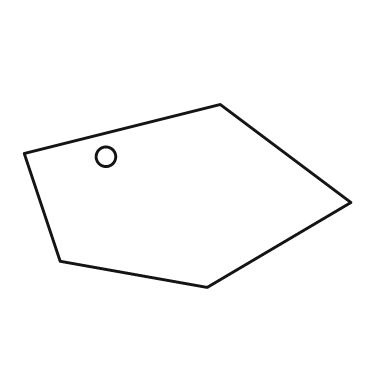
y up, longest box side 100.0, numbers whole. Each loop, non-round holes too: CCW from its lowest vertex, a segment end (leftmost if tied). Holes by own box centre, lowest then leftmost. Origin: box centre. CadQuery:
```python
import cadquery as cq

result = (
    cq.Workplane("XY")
    .moveTo(6.0, -28.0)
    .lineTo(50.0, -2.0)
    .lineTo(10.0, 28.0)
    .lineTo(-50.0, 13.0)
    .lineTo(-39.0, -20.0)
    .close()
    .moveTo(-25.0, 12.0)
    .circle(3.0)
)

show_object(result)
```